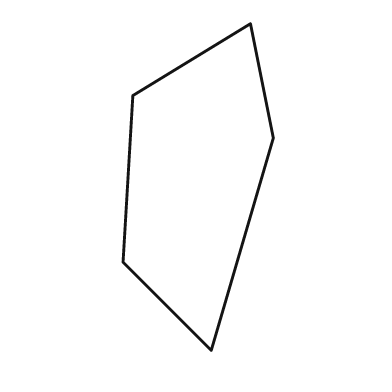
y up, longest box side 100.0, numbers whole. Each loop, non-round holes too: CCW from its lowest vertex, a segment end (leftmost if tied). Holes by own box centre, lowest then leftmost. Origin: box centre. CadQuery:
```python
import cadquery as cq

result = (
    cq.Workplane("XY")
    .moveTo(4.0, -50.0)
    .lineTo(23.0, 15.0)
    .lineTo(16.0, 50.0)
    .lineTo(-20.0, 28.0)
    .lineTo(-23.0, -23.0)
    .close()
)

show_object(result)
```